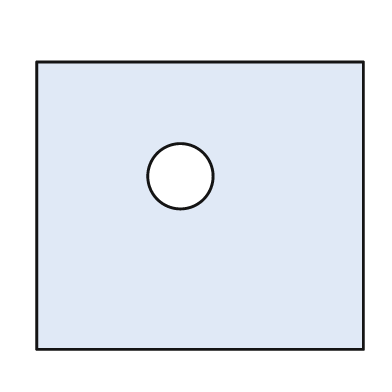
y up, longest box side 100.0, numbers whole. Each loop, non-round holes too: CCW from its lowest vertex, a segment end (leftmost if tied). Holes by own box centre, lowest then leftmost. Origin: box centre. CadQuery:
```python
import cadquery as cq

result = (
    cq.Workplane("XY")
    .moveTo(-50.0, -44.0)
    .lineTo(50.0, -44.0)
    .lineTo(50.0, 44.0)
    .lineTo(-50.0, 44.0)
    .close()
    .moveTo(-6.0, 9.0)
    .circle(10.0)
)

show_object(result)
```